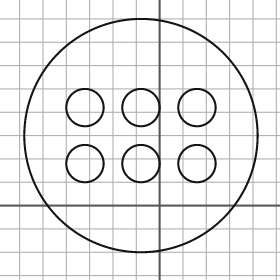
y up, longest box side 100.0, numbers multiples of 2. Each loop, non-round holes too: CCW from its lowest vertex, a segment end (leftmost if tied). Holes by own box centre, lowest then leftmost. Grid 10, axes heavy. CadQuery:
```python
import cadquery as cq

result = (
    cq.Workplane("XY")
    .moveTo(-8.0, 30.0)
    .circle(50.0)
    .moveTo(-32.0, 18.0)
    .circle(8.0)
    .moveTo(-8.0, 18.0)
    .circle(8.0)
    .moveTo(16.0, 18.0)
    .circle(8.0)
    .moveTo(-32.0, 42.0)
    .circle(8.0)
    .moveTo(-8.0, 42.0)
    .circle(8.0)
    .moveTo(16.0, 42.0)
    .circle(8.0)
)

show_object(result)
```